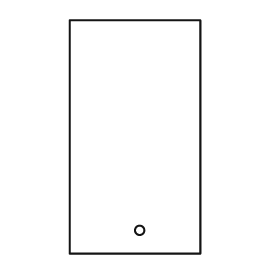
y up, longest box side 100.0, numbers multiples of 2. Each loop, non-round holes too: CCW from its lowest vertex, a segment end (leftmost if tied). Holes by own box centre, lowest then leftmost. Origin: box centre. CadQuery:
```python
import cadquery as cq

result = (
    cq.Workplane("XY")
    .moveTo(-28.0, -50.0)
    .lineTo(28.0, -50.0)
    .lineTo(28.0, 50.0)
    .lineTo(-28.0, 50.0)
    .close()
    .moveTo(2.0, -40.0)
    .circle(2.0)
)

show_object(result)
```